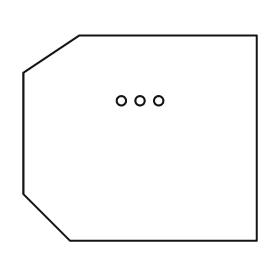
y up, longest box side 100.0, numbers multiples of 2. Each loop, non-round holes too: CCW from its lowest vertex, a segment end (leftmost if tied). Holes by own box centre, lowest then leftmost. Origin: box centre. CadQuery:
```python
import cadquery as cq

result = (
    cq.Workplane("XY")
    .moveTo(-30.0, -44.0)
    .lineTo(50.0, -44.0)
    .lineTo(50.0, 44.0)
    .lineTo(-26.0, 44.0)
    .lineTo(-50.0, 28.0)
    .lineTo(-50.0, -24.0)
    .close()
    .moveTo(-8.0, 16.0)
    .circle(2.0)
    .moveTo(0.0, 16.0)
    .circle(2.0)
    .moveTo(8.0, 16.0)
    .circle(2.0)
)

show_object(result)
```